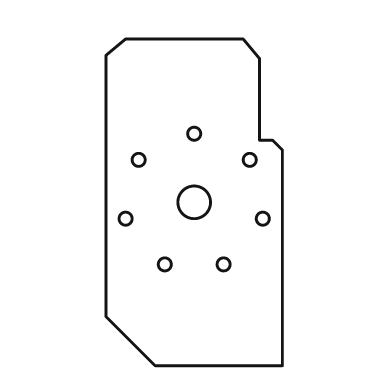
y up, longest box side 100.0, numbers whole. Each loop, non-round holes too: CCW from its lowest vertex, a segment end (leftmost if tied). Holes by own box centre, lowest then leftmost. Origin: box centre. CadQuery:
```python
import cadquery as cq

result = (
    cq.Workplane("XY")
    .moveTo(-12.0, -50.0)
    .lineTo(27.0, -50.0)
    .lineTo(27.0, 16.0)
    .lineTo(24.0, 19.0)
    .lineTo(20.0, 19.0)
    .lineTo(20.0, 44.0)
    .lineTo(15.0, 50.0)
    .lineTo(-21.0, 50.0)
    .lineTo(-27.0, 45.0)
    .lineTo(-27.0, -35.0)
    .close()
    .moveTo(-9.0, -19.0)
    .circle(2.0)
    .moveTo(9.0, -19.0)
    .circle(2.0)
    .moveTo(-21.0, -5.0)
    .circle(2.0)
    .moveTo(21.0, -5.0)
    .circle(2.0)
    .moveTo(0.0, 0.0)
    .circle(5.0)
    .moveTo(-17.0, 13.0)
    .circle(2.0)
    .moveTo(17.0, 13.0)
    .circle(2.0)
    .moveTo(0.0, 21.0)
    .circle(2.0)
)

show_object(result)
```